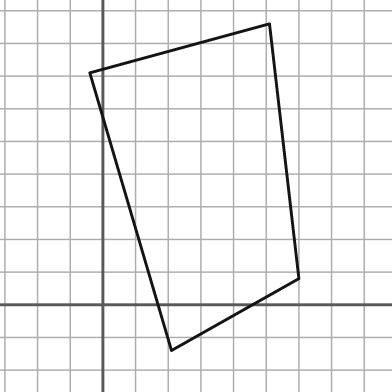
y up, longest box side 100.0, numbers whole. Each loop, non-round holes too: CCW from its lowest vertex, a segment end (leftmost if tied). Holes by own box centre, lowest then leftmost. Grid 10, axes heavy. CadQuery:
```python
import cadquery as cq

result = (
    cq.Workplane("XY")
    .moveTo(21.0, -14.0)
    .lineTo(60.0, 8.0)
    .lineTo(51.0, 86.0)
    .lineTo(-4.0, 71.0)
    .close()
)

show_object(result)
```